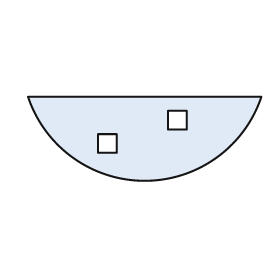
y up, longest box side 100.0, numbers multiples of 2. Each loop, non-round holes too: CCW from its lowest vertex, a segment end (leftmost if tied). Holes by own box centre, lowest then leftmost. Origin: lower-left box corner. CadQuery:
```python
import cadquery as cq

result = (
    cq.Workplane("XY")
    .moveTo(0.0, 36.0)
    .threePointArc((50.0, 0.0), (100.0, 36.0))
    .close()
    .moveTo(30.0, 12.0)
    .lineTo(38.0, 12.0)
    .lineTo(38.0, 20.0)
    .lineTo(30.0, 20.0)
    .close()
    .moveTo(60.0, 22.0)
    .lineTo(68.0, 22.0)
    .lineTo(68.0, 30.0)
    .lineTo(60.0, 30.0)
    .close()
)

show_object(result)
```